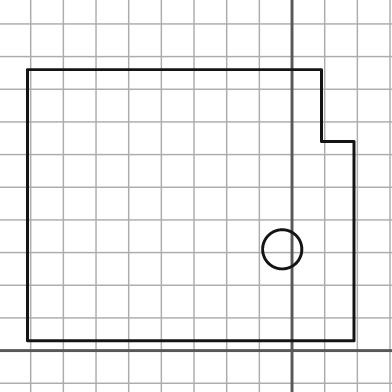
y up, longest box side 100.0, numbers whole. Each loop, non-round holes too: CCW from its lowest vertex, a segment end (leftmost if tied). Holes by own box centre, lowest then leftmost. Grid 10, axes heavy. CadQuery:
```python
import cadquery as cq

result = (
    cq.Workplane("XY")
    .moveTo(-81.0, 3.0)
    .lineTo(19.0, 3.0)
    .lineTo(19.0, 64.0)
    .lineTo(9.0, 64.0)
    .lineTo(9.0, 86.0)
    .lineTo(-81.0, 86.0)
    .close()
    .moveTo(-3.0, 31.0)
    .circle(6.0)
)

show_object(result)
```